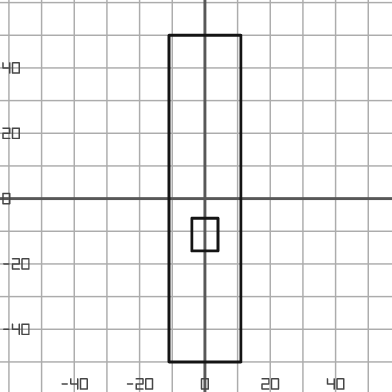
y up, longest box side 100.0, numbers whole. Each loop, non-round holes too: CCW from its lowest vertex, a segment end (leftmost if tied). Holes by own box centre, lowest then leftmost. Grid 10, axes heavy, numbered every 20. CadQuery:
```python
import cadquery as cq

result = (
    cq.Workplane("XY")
    .moveTo(-11.0, -50.0)
    .lineTo(11.0, -50.0)
    .lineTo(11.0, 50.0)
    .lineTo(-11.0, 50.0)
    .close()
    .moveTo(-4.0, -16.0)
    .lineTo(4.0, -16.0)
    .lineTo(4.0, -6.0)
    .lineTo(-4.0, -6.0)
    .close()
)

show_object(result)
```